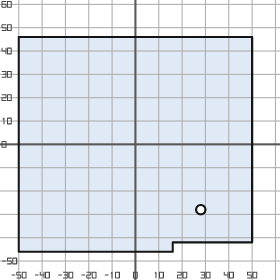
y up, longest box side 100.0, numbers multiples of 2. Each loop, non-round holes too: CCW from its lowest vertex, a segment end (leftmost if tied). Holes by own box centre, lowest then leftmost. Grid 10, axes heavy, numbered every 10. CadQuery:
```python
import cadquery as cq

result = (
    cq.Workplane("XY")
    .moveTo(-50.0, -46.0)
    .lineTo(16.0, -46.0)
    .lineTo(16.0, -42.0)
    .lineTo(50.0, -42.0)
    .lineTo(50.0, 46.0)
    .lineTo(-50.0, 46.0)
    .close()
    .moveTo(28.0, -28.0)
    .circle(2.0)
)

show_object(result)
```